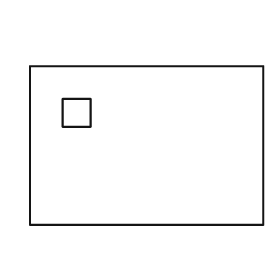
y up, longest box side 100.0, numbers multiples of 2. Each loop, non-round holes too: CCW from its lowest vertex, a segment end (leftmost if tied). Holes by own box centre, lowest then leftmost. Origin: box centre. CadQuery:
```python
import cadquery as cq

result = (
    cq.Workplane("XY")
    .moveTo(-50.0, -34.0)
    .lineTo(50.0, -34.0)
    .lineTo(50.0, 34.0)
    .lineTo(-50.0, 34.0)
    .close()
    .moveTo(-36.0, 8.0)
    .lineTo(-24.0, 8.0)
    .lineTo(-24.0, 20.0)
    .lineTo(-36.0, 20.0)
    .close()
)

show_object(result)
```